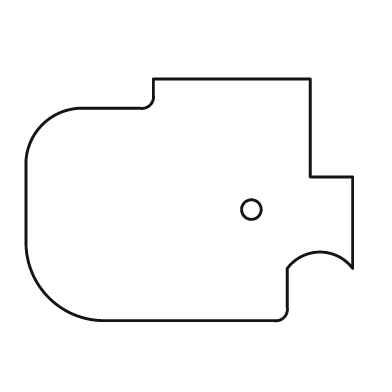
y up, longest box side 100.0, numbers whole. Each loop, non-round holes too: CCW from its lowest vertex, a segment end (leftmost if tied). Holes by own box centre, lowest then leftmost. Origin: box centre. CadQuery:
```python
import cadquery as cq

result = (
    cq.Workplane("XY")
    .moveTo(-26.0, -37.0)
    .lineTo(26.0, -37.0)
    .threePointArc((29.0, -36.0), (30.0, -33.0))
    .lineTo(30.0, -21.0)
    .threePointArc((40.0, -16.0), (50.0, -21.0))
    .lineTo(50.0, 7.0)
    .lineTo(37.0, 7.0)
    .lineTo(37.0, 37.0)
    .lineTo(-11.0, 37.0)
    .lineTo(-11.0, 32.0)
    .threePointArc((-12.0, 29.0), (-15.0, 28.0))
    .lineTo(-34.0, 28.0)
    .threePointArc((-45.0, 23.0), (-50.0, 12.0))
    .lineTo(-50.0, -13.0)
    .threePointArc((-43.0, -30.0), (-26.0, -37.0))
    .close()
    .moveTo(19.0, -3.0)
    .circle(3.0)
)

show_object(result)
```